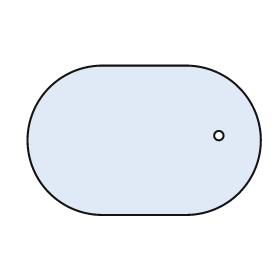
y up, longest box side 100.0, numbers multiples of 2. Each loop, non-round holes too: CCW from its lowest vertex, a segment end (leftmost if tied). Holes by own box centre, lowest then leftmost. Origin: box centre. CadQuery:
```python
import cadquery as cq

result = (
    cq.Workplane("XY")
    .moveTo(-18.0, -32.0)
    .lineTo(18.0, -32.0)
    .threePointArc((50.0, 0.0), (18.0, 32.0))
    .lineTo(-18.0, 32.0)
    .threePointArc((-50.0, 0.0), (-18.0, -32.0))
    .close()
    .moveTo(32.0, 2.0)
    .circle(2.0)
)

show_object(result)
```